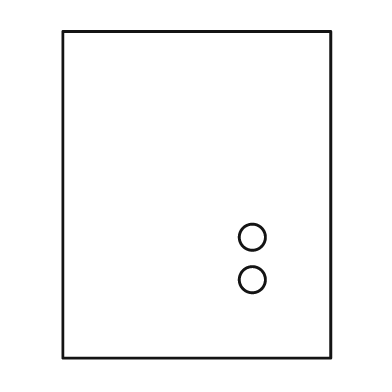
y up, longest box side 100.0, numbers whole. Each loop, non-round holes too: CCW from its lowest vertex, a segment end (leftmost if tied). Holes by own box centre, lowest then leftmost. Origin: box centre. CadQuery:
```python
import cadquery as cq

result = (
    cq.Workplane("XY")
    .moveTo(-41.0, -50.0)
    .lineTo(41.0, -50.0)
    .lineTo(41.0, 50.0)
    .lineTo(-41.0, 50.0)
    .close()
    .moveTo(17.0, -26.0)
    .circle(4.0)
    .moveTo(17.0, -13.0)
    .circle(4.0)
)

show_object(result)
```